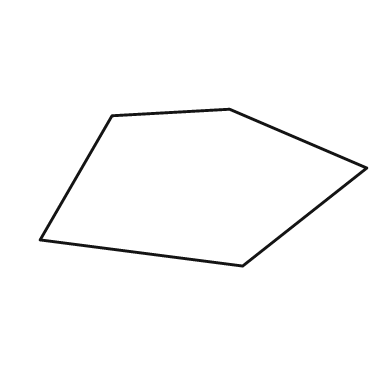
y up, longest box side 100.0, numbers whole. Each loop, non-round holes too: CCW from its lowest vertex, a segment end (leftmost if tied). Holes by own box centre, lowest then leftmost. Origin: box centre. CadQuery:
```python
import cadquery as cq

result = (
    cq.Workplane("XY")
    .moveTo(12.0, -24.0)
    .lineTo(50.0, 6.0)
    .lineTo(8.0, 24.0)
    .lineTo(-28.0, 22.0)
    .lineTo(-50.0, -16.0)
    .close()
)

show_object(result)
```